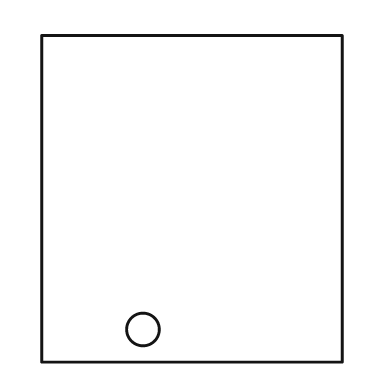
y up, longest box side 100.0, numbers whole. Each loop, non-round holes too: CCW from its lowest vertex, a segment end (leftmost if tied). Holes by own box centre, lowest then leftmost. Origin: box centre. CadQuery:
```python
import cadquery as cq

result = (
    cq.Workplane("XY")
    .moveTo(-46.0, -50.0)
    .lineTo(46.0, -50.0)
    .lineTo(46.0, 50.0)
    .lineTo(-46.0, 50.0)
    .close()
    .moveTo(-15.0, -40.0)
    .circle(5.0)
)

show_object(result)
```